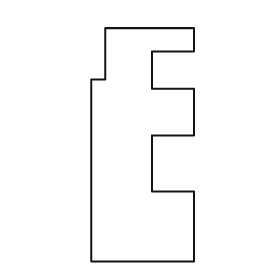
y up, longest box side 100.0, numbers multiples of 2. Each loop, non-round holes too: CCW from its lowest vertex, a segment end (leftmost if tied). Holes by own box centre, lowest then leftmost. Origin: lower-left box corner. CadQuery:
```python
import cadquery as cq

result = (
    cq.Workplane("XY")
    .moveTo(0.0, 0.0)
    .lineTo(44.0, 0.0)
    .lineTo(44.0, 30.0)
    .lineTo(26.0, 30.0)
    .lineTo(26.0, 54.0)
    .lineTo(44.0, 54.0)
    .lineTo(44.0, 74.0)
    .lineTo(26.0, 74.0)
    .lineTo(26.0, 90.0)
    .lineTo(44.0, 90.0)
    .lineTo(44.0, 100.0)
    .lineTo(6.0, 100.0)
    .lineTo(6.0, 78.0)
    .lineTo(0.0, 78.0)
    .close()
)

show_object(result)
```